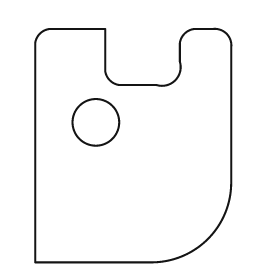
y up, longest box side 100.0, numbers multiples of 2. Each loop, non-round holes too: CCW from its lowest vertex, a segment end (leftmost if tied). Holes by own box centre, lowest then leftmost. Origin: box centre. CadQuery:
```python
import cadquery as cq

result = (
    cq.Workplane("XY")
    .moveTo(-42.0, -50.0)
    .lineTo(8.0, -50.0)
    .threePointArc((32.0, -40.0), (42.0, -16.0))
    .lineTo(42.0, 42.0)
    .threePointArc((40.0, 48.0), (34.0, 50.0))
    .lineTo(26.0, 50.0)
    .threePointArc((22.0, 48.0), (20.0, 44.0))
    .lineTo(20.0, 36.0)
    .threePointArc((18.0, 28.0), (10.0, 26.0))
    .lineTo(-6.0, 26.0)
    .threePointArc((-10.0, 28.0), (-12.0, 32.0))
    .lineTo(-12.0, 50.0)
    .lineTo(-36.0, 50.0)
    .threePointArc((-40.0, 48.0), (-42.0, 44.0))
    .close()
    .moveTo(-16.0, 10.0)
    .circle(10.0)
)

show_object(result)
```